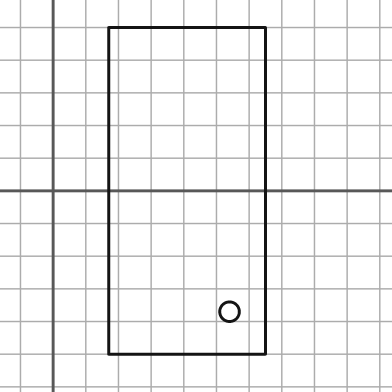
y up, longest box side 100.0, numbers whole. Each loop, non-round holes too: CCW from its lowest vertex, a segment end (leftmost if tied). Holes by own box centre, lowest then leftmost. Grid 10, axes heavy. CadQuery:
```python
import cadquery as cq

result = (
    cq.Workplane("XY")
    .moveTo(17.0, -50.0)
    .lineTo(65.0, -50.0)
    .lineTo(65.0, 50.0)
    .lineTo(17.0, 50.0)
    .close()
    .moveTo(54.0, -37.0)
    .circle(3.0)
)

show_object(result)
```